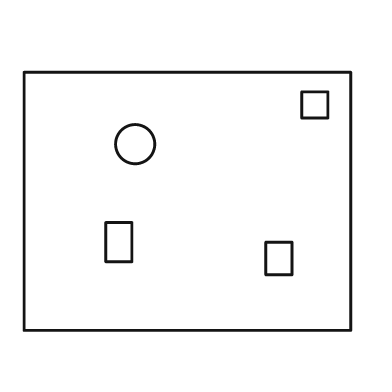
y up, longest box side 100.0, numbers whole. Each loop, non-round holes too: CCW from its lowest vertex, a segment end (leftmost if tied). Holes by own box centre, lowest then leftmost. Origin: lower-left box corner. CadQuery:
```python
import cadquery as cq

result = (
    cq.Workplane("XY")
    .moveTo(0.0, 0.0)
    .lineTo(100.0, 0.0)
    .lineTo(100.0, 79.0)
    .lineTo(0.0, 79.0)
    .close()
    .moveTo(74.0, 17.0)
    .lineTo(82.0, 17.0)
    .lineTo(82.0, 27.0)
    .lineTo(74.0, 27.0)
    .close()
    .moveTo(25.0, 21.0)
    .lineTo(33.0, 21.0)
    .lineTo(33.0, 33.0)
    .lineTo(25.0, 33.0)
    .close()
    .moveTo(34.0, 57.0)
    .circle(6.0)
    .moveTo(85.0, 65.0)
    .lineTo(93.0, 65.0)
    .lineTo(93.0, 73.0)
    .lineTo(85.0, 73.0)
    .close()
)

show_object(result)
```